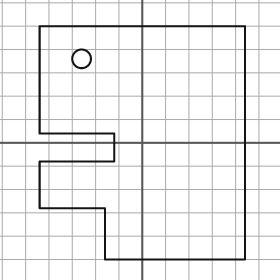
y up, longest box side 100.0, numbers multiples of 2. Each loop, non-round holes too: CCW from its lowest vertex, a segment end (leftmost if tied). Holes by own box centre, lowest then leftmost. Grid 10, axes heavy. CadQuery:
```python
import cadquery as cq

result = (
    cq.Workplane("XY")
    .moveTo(-16.0, -50.0)
    .lineTo(44.0, -50.0)
    .lineTo(44.0, 50.0)
    .lineTo(-44.0, 50.0)
    .lineTo(-44.0, 4.0)
    .lineTo(-12.0, 4.0)
    .lineTo(-12.0, -8.0)
    .lineTo(-44.0, -8.0)
    .lineTo(-44.0, -28.0)
    .lineTo(-16.0, -28.0)
    .close()
    .moveTo(-26.0, 36.0)
    .circle(4.0)
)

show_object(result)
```